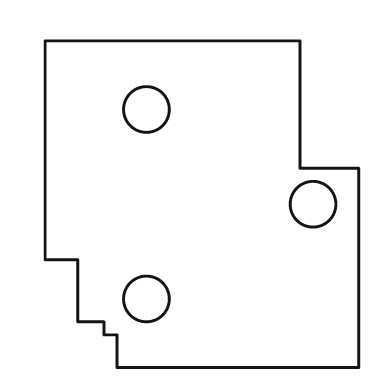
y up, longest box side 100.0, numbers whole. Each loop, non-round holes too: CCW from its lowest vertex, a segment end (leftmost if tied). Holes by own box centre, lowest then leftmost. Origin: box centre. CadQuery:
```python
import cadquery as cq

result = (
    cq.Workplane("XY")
    .moveTo(-26.0, -50.0)
    .lineTo(48.0, -50.0)
    .lineTo(48.0, 11.0)
    .lineTo(30.0, 11.0)
    .lineTo(30.0, 50.0)
    .lineTo(-48.0, 50.0)
    .lineTo(-48.0, -17.0)
    .lineTo(-38.0, -17.0)
    .lineTo(-38.0, -36.0)
    .lineTo(-30.0, -36.0)
    .lineTo(-30.0, -40.0)
    .lineTo(-26.0, -40.0)
    .close()
    .moveTo(-17.0, -29.0)
    .circle(7.0)
    .moveTo(34.0, 0.0)
    .circle(7.0)
    .moveTo(-17.0, 29.0)
    .circle(7.0)
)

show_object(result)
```